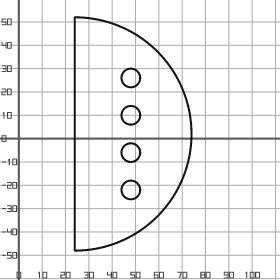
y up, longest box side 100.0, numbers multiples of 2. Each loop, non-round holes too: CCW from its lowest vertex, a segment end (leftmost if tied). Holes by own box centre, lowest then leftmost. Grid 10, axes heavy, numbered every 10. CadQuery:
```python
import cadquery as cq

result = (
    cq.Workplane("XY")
    .moveTo(24.0, -48.0)
    .threePointArc((74.0, 2.0), (24.0, 52.0))
    .close()
    .moveTo(48.0, -22.0)
    .circle(4.0)
    .moveTo(48.0, -6.0)
    .circle(4.0)
    .moveTo(48.0, 10.0)
    .circle(4.0)
    .moveTo(48.0, 26.0)
    .circle(4.0)
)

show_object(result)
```